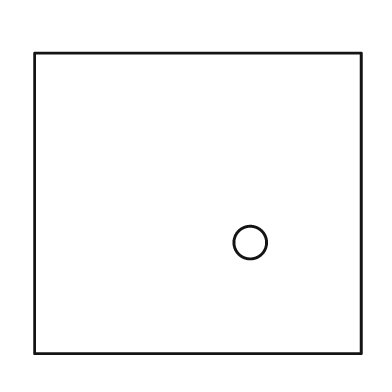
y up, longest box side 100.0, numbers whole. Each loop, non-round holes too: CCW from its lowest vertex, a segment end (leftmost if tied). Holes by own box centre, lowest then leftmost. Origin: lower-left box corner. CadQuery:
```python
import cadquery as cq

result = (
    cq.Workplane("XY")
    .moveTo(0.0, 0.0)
    .lineTo(100.0, 0.0)
    .lineTo(100.0, 92.0)
    .lineTo(0.0, 92.0)
    .close()
    .moveTo(66.0, 34.0)
    .circle(5.0)
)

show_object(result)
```